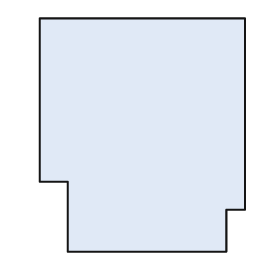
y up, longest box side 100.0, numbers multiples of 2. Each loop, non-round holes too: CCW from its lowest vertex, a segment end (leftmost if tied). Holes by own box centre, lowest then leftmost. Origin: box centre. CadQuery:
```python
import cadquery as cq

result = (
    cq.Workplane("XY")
    .moveTo(-32.0, -50.0)
    .lineTo(36.0, -50.0)
    .lineTo(36.0, -32.0)
    .lineTo(44.0, -32.0)
    .lineTo(44.0, 50.0)
    .lineTo(-44.0, 50.0)
    .lineTo(-44.0, -20.0)
    .lineTo(-32.0, -20.0)
    .close()
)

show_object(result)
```